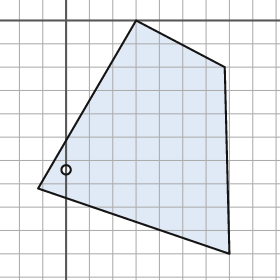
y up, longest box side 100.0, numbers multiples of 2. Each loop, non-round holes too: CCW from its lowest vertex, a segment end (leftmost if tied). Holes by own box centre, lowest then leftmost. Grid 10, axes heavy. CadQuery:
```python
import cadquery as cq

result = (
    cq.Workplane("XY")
    .moveTo(70.0, -100.0)
    .lineTo(68.0, -20.0)
    .lineTo(30.0, 0.0)
    .lineTo(-12.0, -72.0)
    .close()
    .moveTo(0.0, -64.0)
    .circle(2.0)
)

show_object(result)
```